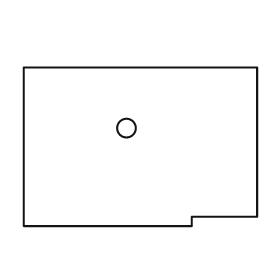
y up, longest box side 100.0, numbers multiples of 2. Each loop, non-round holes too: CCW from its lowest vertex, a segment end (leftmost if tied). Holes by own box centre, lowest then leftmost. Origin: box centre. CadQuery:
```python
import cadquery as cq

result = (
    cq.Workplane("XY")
    .moveTo(-50.0, -34.0)
    .lineTo(22.0, -34.0)
    .lineTo(22.0, -30.0)
    .lineTo(50.0, -30.0)
    .lineTo(50.0, 34.0)
    .lineTo(-50.0, 34.0)
    .close()
    .moveTo(-6.0, 8.0)
    .circle(4.0)
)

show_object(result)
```